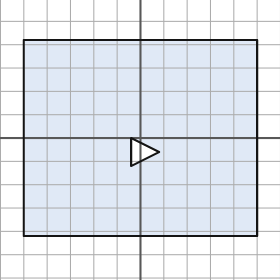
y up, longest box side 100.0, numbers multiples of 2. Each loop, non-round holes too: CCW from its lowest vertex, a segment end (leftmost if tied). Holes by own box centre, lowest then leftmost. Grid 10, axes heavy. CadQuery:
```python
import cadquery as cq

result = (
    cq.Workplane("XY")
    .moveTo(-50.0, -42.0)
    .lineTo(50.0, -42.0)
    .lineTo(50.0, 42.0)
    .lineTo(-50.0, 42.0)
    .close()
    .moveTo(-4.0, -12.0)
    .lineTo(8.0, -6.0)
    .lineTo(-4.0, 0.0)
    .close()
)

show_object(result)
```